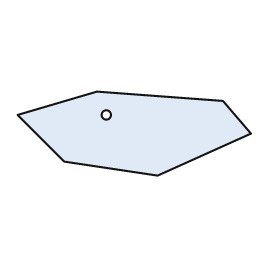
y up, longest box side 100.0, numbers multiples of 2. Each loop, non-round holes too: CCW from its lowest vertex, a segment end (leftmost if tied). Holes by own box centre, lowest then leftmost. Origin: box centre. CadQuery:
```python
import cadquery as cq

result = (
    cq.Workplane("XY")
    .moveTo(10.0, -18.0)
    .lineTo(50.0, 0.0)
    .lineTo(38.0, 14.0)
    .lineTo(-16.0, 18.0)
    .lineTo(-50.0, 8.0)
    .lineTo(-30.0, -12.0)
    .close()
    .moveTo(-12.0, 8.0)
    .circle(2.0)
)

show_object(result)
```